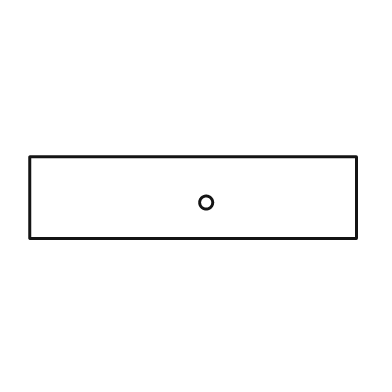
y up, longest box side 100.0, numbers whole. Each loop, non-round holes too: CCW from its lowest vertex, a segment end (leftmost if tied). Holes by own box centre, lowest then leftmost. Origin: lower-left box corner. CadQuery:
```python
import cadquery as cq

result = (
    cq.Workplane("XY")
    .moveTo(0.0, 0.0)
    .lineTo(100.0, 0.0)
    .lineTo(100.0, 25.0)
    .lineTo(0.0, 25.0)
    .close()
    .moveTo(54.0, 11.0)
    .circle(2.0)
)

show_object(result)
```